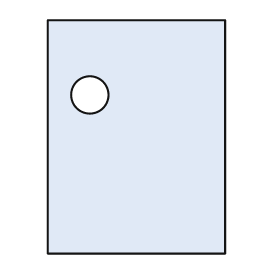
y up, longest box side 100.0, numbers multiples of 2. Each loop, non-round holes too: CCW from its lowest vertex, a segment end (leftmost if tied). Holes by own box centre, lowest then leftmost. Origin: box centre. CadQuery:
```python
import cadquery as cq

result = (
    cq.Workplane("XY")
    .moveTo(-38.0, -50.0)
    .lineTo(38.0, -50.0)
    .lineTo(38.0, 50.0)
    .lineTo(-38.0, 50.0)
    .close()
    .moveTo(-20.0, 18.0)
    .circle(8.0)
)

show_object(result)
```